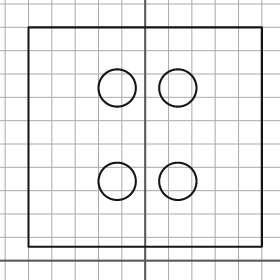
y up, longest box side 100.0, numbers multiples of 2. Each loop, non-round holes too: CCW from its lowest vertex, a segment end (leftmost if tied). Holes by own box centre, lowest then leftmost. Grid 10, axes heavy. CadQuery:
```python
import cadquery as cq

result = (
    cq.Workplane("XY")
    .moveTo(-50.0, 6.0)
    .lineTo(50.0, 6.0)
    .lineTo(50.0, 100.0)
    .lineTo(-50.0, 100.0)
    .close()
    .moveTo(-12.0, 34.0)
    .circle(8.0)
    .moveTo(14.0, 34.0)
    .circle(8.0)
    .moveTo(-12.0, 74.0)
    .circle(8.0)
    .moveTo(14.0, 74.0)
    .circle(8.0)
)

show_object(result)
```